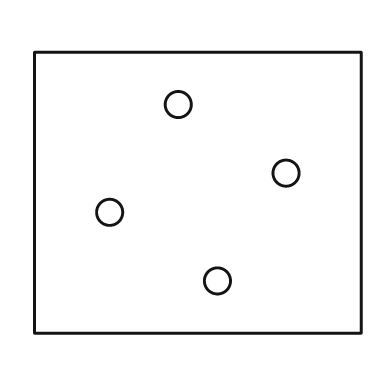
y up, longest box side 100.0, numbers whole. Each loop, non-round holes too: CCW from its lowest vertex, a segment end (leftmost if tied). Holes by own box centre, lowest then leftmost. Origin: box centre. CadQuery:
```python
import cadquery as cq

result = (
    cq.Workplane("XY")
    .moveTo(-50.0, -43.0)
    .lineTo(50.0, -43.0)
    .lineTo(50.0, 43.0)
    .lineTo(-50.0, 43.0)
    .close()
    .moveTo(6.0, -27.0)
    .circle(4.0)
    .moveTo(-27.0, -6.0)
    .circle(4.0)
    .moveTo(27.0, 6.0)
    .circle(4.0)
    .moveTo(-6.0, 27.0)
    .circle(4.0)
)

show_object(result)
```